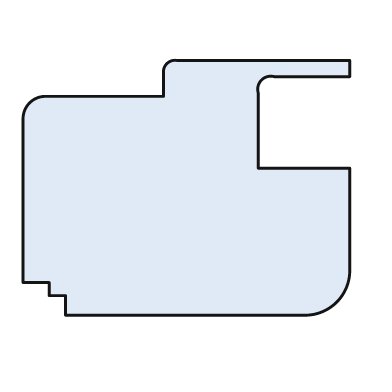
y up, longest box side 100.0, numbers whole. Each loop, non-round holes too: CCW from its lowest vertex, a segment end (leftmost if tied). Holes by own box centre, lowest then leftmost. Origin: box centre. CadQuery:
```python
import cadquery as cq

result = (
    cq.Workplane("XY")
    .moveTo(-37.0, -39.0)
    .lineTo(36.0, -39.0)
    .threePointArc((46.0, -35.0), (50.0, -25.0))
    .lineTo(50.0, 6.0)
    .lineTo(22.0, 6.0)
    .lineTo(22.0, 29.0)
    .threePointArc((23.0, 33.0), (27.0, 34.0))
    .lineTo(50.0, 34.0)
    .lineTo(50.0, 39.0)
    .lineTo(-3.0, 39.0)
    .threePointArc((-6.0, 38.0), (-7.0, 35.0))
    .lineTo(-7.0, 28.0)
    .lineTo(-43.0, 28.0)
    .threePointArc((-48.0, 26.0), (-50.0, 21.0))
    .lineTo(-50.0, -29.0)
    .lineTo(-42.0, -29.0)
    .lineTo(-42.0, -33.0)
    .lineTo(-37.0, -33.0)
    .close()
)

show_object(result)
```